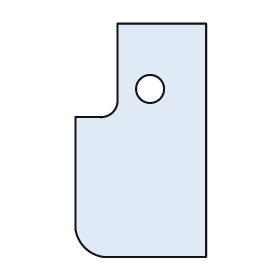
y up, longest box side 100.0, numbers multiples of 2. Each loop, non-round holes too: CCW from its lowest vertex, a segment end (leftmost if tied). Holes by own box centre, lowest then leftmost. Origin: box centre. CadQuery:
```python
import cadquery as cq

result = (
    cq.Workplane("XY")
    .moveTo(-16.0, -50.0)
    .lineTo(28.0, -50.0)
    .lineTo(28.0, 50.0)
    .lineTo(-10.0, 50.0)
    .lineTo(-10.0, 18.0)
    .threePointArc((-12.0, 12.0), (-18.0, 10.0))
    .lineTo(-28.0, 10.0)
    .lineTo(-28.0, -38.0)
    .threePointArc((-24.0, -46.0), (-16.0, -50.0))
    .close()
    .moveTo(4.0, 22.0)
    .circle(6.0)
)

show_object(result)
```